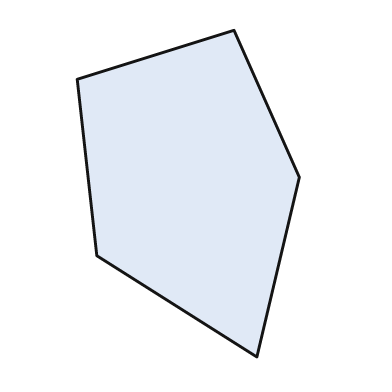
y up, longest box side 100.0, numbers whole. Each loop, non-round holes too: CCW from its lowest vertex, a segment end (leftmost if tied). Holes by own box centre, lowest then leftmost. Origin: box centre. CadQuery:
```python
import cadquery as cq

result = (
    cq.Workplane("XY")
    .moveTo(21.0, -50.0)
    .lineTo(34.0, 5.0)
    .lineTo(14.0, 50.0)
    .lineTo(-34.0, 35.0)
    .lineTo(-28.0, -19.0)
    .close()
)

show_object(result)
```